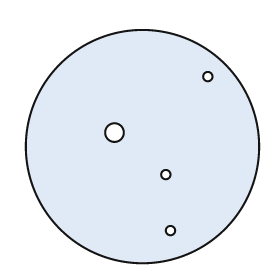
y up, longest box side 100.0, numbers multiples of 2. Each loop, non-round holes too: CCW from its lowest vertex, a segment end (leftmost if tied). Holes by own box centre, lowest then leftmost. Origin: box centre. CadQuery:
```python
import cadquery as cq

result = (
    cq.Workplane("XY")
    .moveTo(0.0, 0.0)
    .circle(50.0)
    .moveTo(12.0, -36.0)
    .circle(2.0)
    .moveTo(10.0, -12.0)
    .circle(2.0)
    .moveTo(-12.0, 6.0)
    .circle(4.0)
    .moveTo(28.0, 30.0)
    .circle(2.0)
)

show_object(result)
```